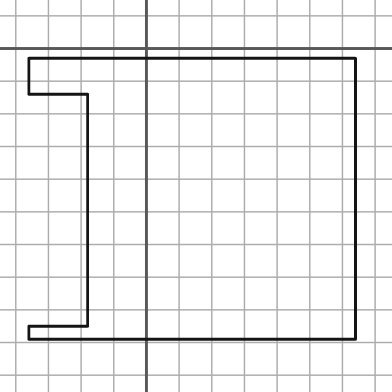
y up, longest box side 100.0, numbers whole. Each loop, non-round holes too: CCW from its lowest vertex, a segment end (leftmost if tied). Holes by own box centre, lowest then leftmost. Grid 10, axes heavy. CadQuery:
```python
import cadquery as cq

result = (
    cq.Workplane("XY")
    .moveTo(-36.0, -89.0)
    .lineTo(64.0, -89.0)
    .lineTo(64.0, -3.0)
    .lineTo(-36.0, -3.0)
    .lineTo(-36.0, -14.0)
    .lineTo(-18.0, -14.0)
    .lineTo(-18.0, -85.0)
    .lineTo(-36.0, -85.0)
    .close()
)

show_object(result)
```